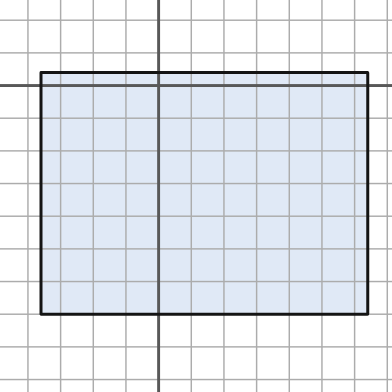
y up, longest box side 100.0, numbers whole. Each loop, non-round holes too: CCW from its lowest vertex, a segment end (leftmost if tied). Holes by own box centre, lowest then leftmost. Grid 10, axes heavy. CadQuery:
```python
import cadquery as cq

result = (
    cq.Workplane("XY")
    .moveTo(-36.0, -70.0)
    .lineTo(64.0, -70.0)
    .lineTo(64.0, 4.0)
    .lineTo(-36.0, 4.0)
    .close()
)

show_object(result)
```